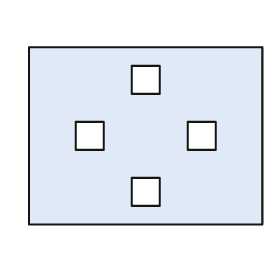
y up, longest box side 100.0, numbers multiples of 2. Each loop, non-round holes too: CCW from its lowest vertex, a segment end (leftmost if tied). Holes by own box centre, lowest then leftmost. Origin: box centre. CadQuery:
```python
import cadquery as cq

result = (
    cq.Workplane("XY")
    .moveTo(-50.0, -38.0)
    .lineTo(50.0, -38.0)
    .lineTo(50.0, 38.0)
    .lineTo(-50.0, 38.0)
    .close()
    .moveTo(-6.0, -30.0)
    .lineTo(6.0, -30.0)
    .lineTo(6.0, -18.0)
    .lineTo(-6.0, -18.0)
    .close()
    .moveTo(-30.0, -6.0)
    .lineTo(-18.0, -6.0)
    .lineTo(-18.0, 6.0)
    .lineTo(-30.0, 6.0)
    .close()
    .moveTo(18.0, -6.0)
    .lineTo(30.0, -6.0)
    .lineTo(30.0, 6.0)
    .lineTo(18.0, 6.0)
    .close()
    .moveTo(-6.0, 18.0)
    .lineTo(6.0, 18.0)
    .lineTo(6.0, 30.0)
    .lineTo(-6.0, 30.0)
    .close()
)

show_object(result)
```